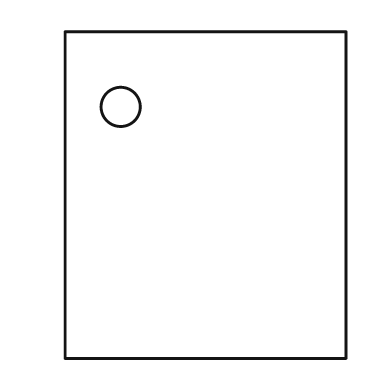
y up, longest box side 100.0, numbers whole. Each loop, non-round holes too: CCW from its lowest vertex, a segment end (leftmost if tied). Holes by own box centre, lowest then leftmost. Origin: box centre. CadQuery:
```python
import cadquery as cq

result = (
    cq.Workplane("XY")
    .moveTo(-43.0, -50.0)
    .lineTo(43.0, -50.0)
    .lineTo(43.0, 50.0)
    .lineTo(-43.0, 50.0)
    .close()
    .moveTo(-26.0, 27.0)
    .circle(6.0)
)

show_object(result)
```